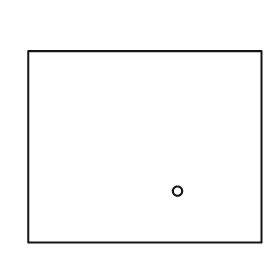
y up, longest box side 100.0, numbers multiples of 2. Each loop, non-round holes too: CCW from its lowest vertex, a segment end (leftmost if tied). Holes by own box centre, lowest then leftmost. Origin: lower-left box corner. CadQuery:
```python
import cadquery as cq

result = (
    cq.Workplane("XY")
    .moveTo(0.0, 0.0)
    .lineTo(100.0, 0.0)
    .lineTo(100.0, 82.0)
    .lineTo(0.0, 82.0)
    .close()
    .moveTo(64.0, 22.0)
    .circle(2.0)
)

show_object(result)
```